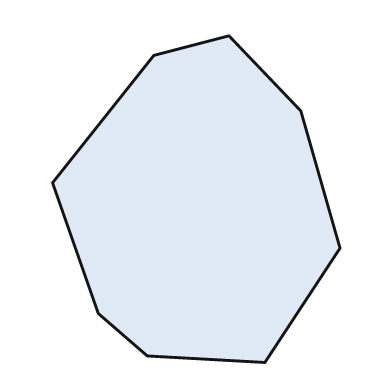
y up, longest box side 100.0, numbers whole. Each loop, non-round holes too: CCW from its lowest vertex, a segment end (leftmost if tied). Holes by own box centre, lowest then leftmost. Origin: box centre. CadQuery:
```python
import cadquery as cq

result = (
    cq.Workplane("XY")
    .moveTo(21.0, -50.0)
    .lineTo(44.0, -15.0)
    .lineTo(32.0, 27.0)
    .lineTo(10.0, 50.0)
    .lineTo(-13.0, 44.0)
    .lineTo(-44.0, 5.0)
    .lineTo(-30.0, -35.0)
    .lineTo(-15.0, -48.0)
    .close()
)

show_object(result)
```